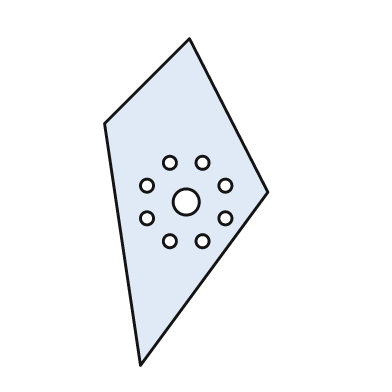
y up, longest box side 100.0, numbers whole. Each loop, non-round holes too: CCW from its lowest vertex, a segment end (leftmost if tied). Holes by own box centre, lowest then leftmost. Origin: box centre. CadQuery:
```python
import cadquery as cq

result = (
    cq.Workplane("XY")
    .moveTo(-14.0, -50.0)
    .lineTo(25.0, 3.0)
    .lineTo(1.0, 50.0)
    .lineTo(-25.0, 24.0)
    .close()
    .moveTo(-5.0, -12.0)
    .circle(2.0)
    .moveTo(5.0, -12.0)
    .circle(2.0)
    .moveTo(-12.0, -5.0)
    .circle(2.0)
    .moveTo(12.0, -5.0)
    .circle(2.0)
    .moveTo(0.0, 0.0)
    .circle(4.0)
    .moveTo(-12.0, 5.0)
    .circle(2.0)
    .moveTo(12.0, 5.0)
    .circle(2.0)
    .moveTo(-5.0, 12.0)
    .circle(2.0)
    .moveTo(5.0, 12.0)
    .circle(2.0)
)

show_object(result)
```